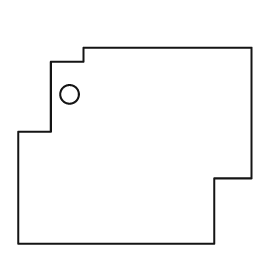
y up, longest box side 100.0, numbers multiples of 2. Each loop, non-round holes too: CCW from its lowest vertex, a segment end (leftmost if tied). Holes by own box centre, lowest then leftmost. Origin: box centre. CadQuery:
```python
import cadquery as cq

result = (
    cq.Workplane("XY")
    .moveTo(-50.0, -42.0)
    .lineTo(34.0, -42.0)
    .lineTo(34.0, -14.0)
    .lineTo(50.0, -14.0)
    .lineTo(50.0, 42.0)
    .lineTo(-22.0, 42.0)
    .lineTo(-22.0, 36.0)
    .lineTo(-36.0, 36.0)
    .lineTo(-36.0, 6.0)
    .lineTo(-50.0, 6.0)
    .close()
    .moveTo(-28.0, 22.0)
    .circle(4.0)
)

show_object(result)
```